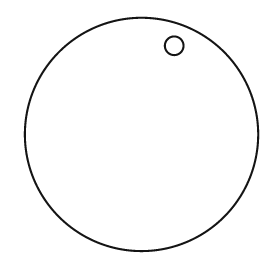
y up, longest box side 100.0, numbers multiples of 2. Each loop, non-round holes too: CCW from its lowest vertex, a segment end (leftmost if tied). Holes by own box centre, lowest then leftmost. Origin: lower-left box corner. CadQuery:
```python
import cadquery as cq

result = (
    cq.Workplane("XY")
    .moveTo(50.0, 50.0)
    .circle(50.0)
    .moveTo(64.0, 88.0)
    .circle(4.0)
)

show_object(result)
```